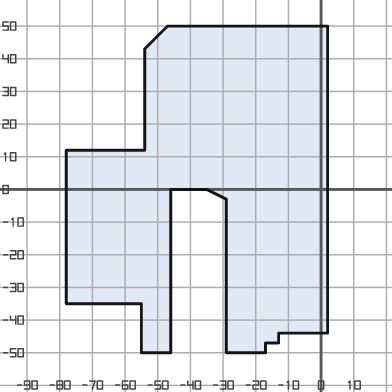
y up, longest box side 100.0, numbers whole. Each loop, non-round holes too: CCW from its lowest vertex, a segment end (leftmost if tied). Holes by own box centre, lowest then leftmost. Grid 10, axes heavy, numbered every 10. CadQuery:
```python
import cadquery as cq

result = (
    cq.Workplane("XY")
    .moveTo(-55.0, -50.0)
    .lineTo(-46.0, -50.0)
    .lineTo(-46.0, 0.0)
    .lineTo(-35.0, 0.0)
    .lineTo(-29.0, -3.0)
    .lineTo(-29.0, -50.0)
    .lineTo(-17.0, -50.0)
    .lineTo(-17.0, -47.0)
    .lineTo(-13.0, -47.0)
    .lineTo(-13.0, -44.0)
    .lineTo(2.0, -44.0)
    .lineTo(2.0, 50.0)
    .lineTo(-47.0, 50.0)
    .lineTo(-54.0, 43.0)
    .lineTo(-54.0, 12.0)
    .lineTo(-78.0, 12.0)
    .lineTo(-78.0, -35.0)
    .lineTo(-55.0, -35.0)
    .close()
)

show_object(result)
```